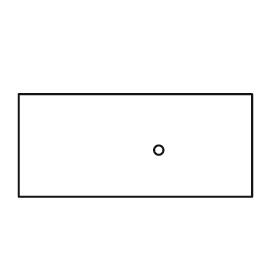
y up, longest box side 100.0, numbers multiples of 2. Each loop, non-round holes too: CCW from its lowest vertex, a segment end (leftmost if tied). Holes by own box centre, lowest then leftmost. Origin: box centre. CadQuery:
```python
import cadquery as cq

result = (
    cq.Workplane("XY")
    .moveTo(-50.0, -22.0)
    .lineTo(50.0, -22.0)
    .lineTo(50.0, 22.0)
    .lineTo(-50.0, 22.0)
    .close()
    .moveTo(10.0, -2.0)
    .circle(2.0)
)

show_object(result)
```